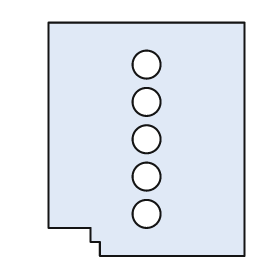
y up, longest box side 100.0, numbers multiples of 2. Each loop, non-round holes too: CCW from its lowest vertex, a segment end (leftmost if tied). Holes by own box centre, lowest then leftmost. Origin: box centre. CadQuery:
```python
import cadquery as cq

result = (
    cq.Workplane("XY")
    .moveTo(-20.0, -50.0)
    .lineTo(42.0, -50.0)
    .lineTo(42.0, 50.0)
    .lineTo(-42.0, 50.0)
    .lineTo(-42.0, -38.0)
    .lineTo(-24.0, -38.0)
    .lineTo(-24.0, -44.0)
    .lineTo(-20.0, -44.0)
    .close()
    .moveTo(0.0, -32.0)
    .circle(6.0)
    .moveTo(0.0, -16.0)
    .circle(6.0)
    .moveTo(0.0, 0.0)
    .circle(6.0)
    .moveTo(0.0, 16.0)
    .circle(6.0)
    .moveTo(0.0, 32.0)
    .circle(6.0)
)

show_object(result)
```